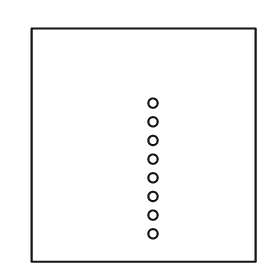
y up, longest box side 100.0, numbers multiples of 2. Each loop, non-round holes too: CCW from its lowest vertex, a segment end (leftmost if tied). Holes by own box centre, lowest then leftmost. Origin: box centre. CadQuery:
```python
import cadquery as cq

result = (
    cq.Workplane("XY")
    .moveTo(-48.0, -50.0)
    .lineTo(48.0, -50.0)
    .lineTo(48.0, 50.0)
    .lineTo(-48.0, 50.0)
    .close()
    .moveTo(4.0, -38.0)
    .circle(2.0)
    .moveTo(4.0, -30.0)
    .circle(2.0)
    .moveTo(4.0, -22.0)
    .circle(2.0)
    .moveTo(4.0, -14.0)
    .circle(2.0)
    .moveTo(4.0, -6.0)
    .circle(2.0)
    .moveTo(4.0, 2.0)
    .circle(2.0)
    .moveTo(4.0, 10.0)
    .circle(2.0)
    .moveTo(4.0, 18.0)
    .circle(2.0)
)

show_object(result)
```